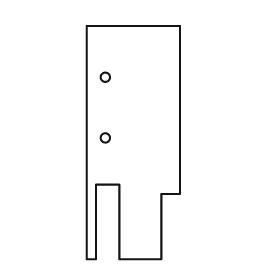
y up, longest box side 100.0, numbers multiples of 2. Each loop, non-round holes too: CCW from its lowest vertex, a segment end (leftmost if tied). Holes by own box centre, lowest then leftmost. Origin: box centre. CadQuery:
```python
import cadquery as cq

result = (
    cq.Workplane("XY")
    .moveTo(-20.0, -50.0)
    .lineTo(-16.0, -50.0)
    .lineTo(-16.0, -18.0)
    .lineTo(-6.0, -18.0)
    .lineTo(-6.0, -50.0)
    .lineTo(12.0, -50.0)
    .lineTo(12.0, -22.0)
    .lineTo(20.0, -22.0)
    .lineTo(20.0, 50.0)
    .lineTo(-20.0, 50.0)
    .close()
    .moveTo(-12.0, 2.0)
    .circle(2.0)
    .moveTo(-12.0, 28.0)
    .circle(2.0)
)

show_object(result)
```